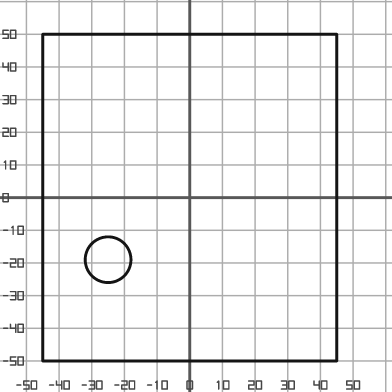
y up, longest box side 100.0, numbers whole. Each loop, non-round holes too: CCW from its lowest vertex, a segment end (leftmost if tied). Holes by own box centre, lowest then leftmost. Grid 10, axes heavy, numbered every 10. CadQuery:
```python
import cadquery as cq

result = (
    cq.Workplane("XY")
    .moveTo(-45.0, -50.0)
    .lineTo(45.0, -50.0)
    .lineTo(45.0, 50.0)
    .lineTo(-45.0, 50.0)
    .close()
    .moveTo(-25.0, -19.0)
    .circle(7.0)
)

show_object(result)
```